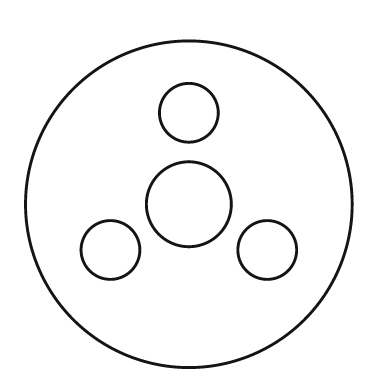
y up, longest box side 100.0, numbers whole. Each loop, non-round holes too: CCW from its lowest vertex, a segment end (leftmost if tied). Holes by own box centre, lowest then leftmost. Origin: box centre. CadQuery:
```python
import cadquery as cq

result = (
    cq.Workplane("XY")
    .moveTo(0.0, 0.0)
    .circle(50.0)
    .moveTo(-24.0, -14.0)
    .circle(9.0)
    .moveTo(24.0, -14.0)
    .circle(9.0)
    .moveTo(0.0, 0.0)
    .circle(13.0)
    .moveTo(0.0, 28.0)
    .circle(9.0)
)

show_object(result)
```